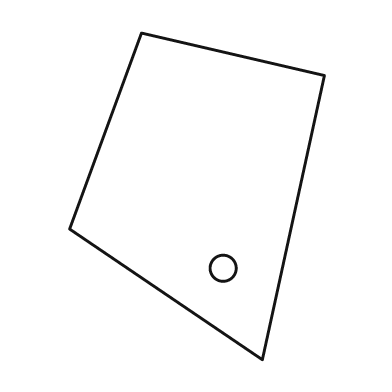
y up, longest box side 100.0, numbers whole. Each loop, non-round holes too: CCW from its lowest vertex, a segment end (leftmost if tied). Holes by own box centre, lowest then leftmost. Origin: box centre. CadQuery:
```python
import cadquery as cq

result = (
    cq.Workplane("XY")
    .moveTo(20.0, -50.0)
    .lineTo(39.0, 37.0)
    .lineTo(-17.0, 50.0)
    .lineTo(-39.0, -10.0)
    .close()
    .moveTo(8.0, -22.0)
    .circle(4.0)
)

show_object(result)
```